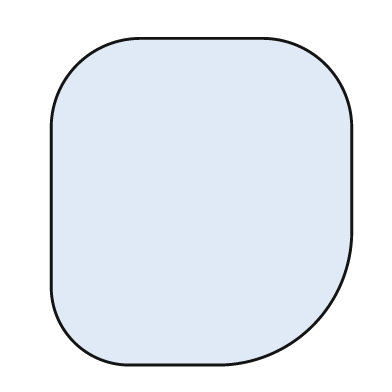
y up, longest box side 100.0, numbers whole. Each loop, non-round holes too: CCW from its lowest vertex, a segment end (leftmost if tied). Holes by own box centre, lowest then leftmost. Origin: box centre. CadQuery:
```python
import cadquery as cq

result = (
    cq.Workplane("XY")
    .moveTo(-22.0, -50.0)
    .lineTo(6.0, -50.0)
    .threePointArc((34.0, -38.0), (46.0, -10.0))
    .lineTo(46.0, 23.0)
    .threePointArc((38.0, 42.0), (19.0, 50.0))
    .lineTo(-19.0, 50.0)
    .threePointArc((-38.0, 42.0), (-46.0, 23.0))
    .lineTo(-46.0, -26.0)
    .threePointArc((-39.0, -43.0), (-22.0, -50.0))
    .close()
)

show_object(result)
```